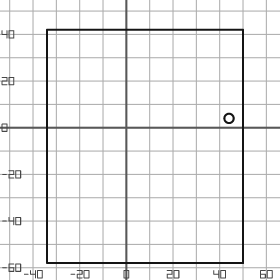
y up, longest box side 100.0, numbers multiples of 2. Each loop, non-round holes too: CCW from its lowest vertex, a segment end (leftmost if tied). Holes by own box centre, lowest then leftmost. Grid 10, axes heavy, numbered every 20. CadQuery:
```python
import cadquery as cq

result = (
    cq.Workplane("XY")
    .moveTo(-34.0, -58.0)
    .lineTo(50.0, -58.0)
    .lineTo(50.0, 42.0)
    .lineTo(-34.0, 42.0)
    .close()
    .moveTo(44.0, 4.0)
    .circle(2.0)
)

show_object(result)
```